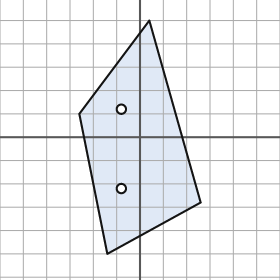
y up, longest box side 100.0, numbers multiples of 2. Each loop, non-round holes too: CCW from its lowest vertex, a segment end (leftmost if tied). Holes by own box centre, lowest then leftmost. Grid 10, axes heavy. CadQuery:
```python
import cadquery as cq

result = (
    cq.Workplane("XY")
    .moveTo(-14.0, -50.0)
    .lineTo(26.0, -28.0)
    .lineTo(4.0, 50.0)
    .lineTo(-26.0, 10.0)
    .close()
    .moveTo(-8.0, -22.0)
    .circle(2.0)
    .moveTo(-8.0, 12.0)
    .circle(2.0)
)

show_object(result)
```